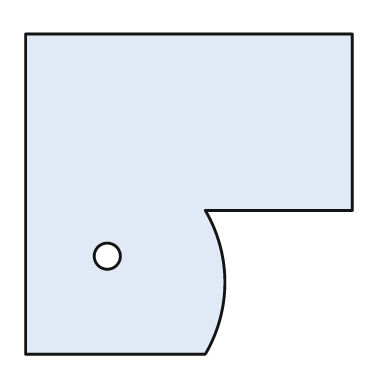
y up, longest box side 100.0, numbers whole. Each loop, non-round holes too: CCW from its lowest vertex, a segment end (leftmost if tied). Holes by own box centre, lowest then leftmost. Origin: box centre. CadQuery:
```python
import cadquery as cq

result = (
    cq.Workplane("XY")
    .moveTo(-50.0, -49.0)
    .lineTo(5.0, -49.0)
    .threePointArc((11.0, -27.0), (5.0, -5.0))
    .lineTo(50.0, -5.0)
    .lineTo(50.0, 49.0)
    .lineTo(-50.0, 49.0)
    .close()
    .moveTo(-25.0, -19.0)
    .circle(4.0)
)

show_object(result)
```